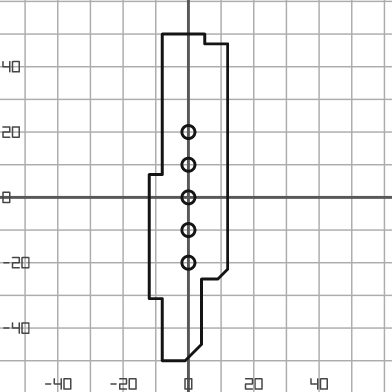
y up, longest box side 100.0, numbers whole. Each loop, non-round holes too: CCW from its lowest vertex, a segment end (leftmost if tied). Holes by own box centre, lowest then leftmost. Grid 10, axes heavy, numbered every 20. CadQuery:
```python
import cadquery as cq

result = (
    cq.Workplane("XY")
    .moveTo(-8.0, -50.0)
    .lineTo(-1.0, -50.0)
    .lineTo(4.0, -45.0)
    .lineTo(4.0, -25.0)
    .lineTo(9.0, -25.0)
    .lineTo(12.0, -22.0)
    .lineTo(12.0, 47.0)
    .lineTo(5.0, 47.0)
    .lineTo(5.0, 50.0)
    .lineTo(-8.0, 50.0)
    .lineTo(-8.0, 7.0)
    .lineTo(-12.0, 7.0)
    .lineTo(-12.0, -31.0)
    .lineTo(-8.0, -31.0)
    .close()
    .moveTo(0.0, -20.0)
    .circle(2.0)
    .moveTo(0.0, -10.0)
    .circle(2.0)
    .moveTo(0.0, 0.0)
    .circle(2.0)
    .moveTo(0.0, 10.0)
    .circle(2.0)
    .moveTo(0.0, 20.0)
    .circle(2.0)
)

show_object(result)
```